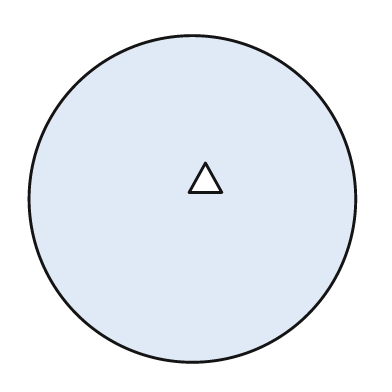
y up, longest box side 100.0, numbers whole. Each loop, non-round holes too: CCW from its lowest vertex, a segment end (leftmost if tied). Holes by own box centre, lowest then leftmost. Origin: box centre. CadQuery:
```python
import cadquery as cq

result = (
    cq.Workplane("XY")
    .moveTo(0.0, 0.0)
    .circle(50.0)
    .moveTo(-1.0, 2.0)
    .lineTo(9.0, 2.0)
    .lineTo(4.0, 11.0)
    .close()
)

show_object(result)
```